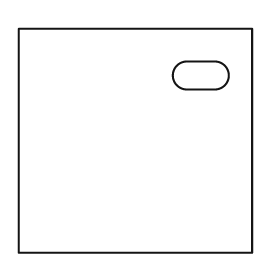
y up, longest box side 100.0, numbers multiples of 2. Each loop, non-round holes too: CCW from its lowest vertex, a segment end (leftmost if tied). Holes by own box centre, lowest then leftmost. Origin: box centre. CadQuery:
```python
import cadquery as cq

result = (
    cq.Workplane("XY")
    .moveTo(-50.0, -48.0)
    .lineTo(50.0, -48.0)
    .lineTo(50.0, 48.0)
    .lineTo(-50.0, 48.0)
    .close()
    .moveTo(22.0, 22.0)
    .lineTo(34.0, 22.0)
    .threePointArc((40.0, 28.0), (34.0, 34.0))
    .lineTo(22.0, 34.0)
    .threePointArc((16.0, 28.0), (22.0, 22.0))
    .close()
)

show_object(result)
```